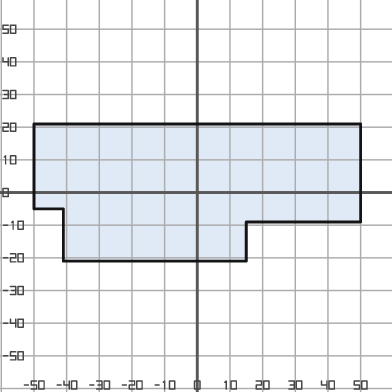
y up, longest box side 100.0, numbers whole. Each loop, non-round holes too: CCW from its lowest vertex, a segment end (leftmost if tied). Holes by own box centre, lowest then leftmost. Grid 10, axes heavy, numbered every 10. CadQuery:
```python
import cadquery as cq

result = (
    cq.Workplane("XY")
    .moveTo(-41.0, -21.0)
    .lineTo(15.0, -21.0)
    .lineTo(15.0, -9.0)
    .lineTo(50.0, -9.0)
    .lineTo(50.0, 21.0)
    .lineTo(-50.0, 21.0)
    .lineTo(-50.0, -5.0)
    .lineTo(-41.0, -5.0)
    .close()
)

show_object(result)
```